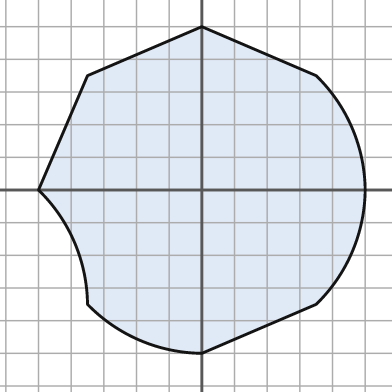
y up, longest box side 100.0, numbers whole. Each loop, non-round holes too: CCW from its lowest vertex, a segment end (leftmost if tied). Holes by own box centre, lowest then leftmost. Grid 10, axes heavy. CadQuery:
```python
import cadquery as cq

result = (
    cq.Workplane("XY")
    .moveTo(0.0, -50.0)
    .lineTo(35.0, -35.0)
    .threePointArc((46.0, -19.0), (50.0, 0.0))
    .threePointArc((46.0, 19.0), (35.0, 35.0))
    .lineTo(0.0, 50.0)
    .lineTo(-35.0, 35.0)
    .lineTo(-50.0, 0.0)
    .threePointArc((-39.0, -16.0), (-35.0, -35.0))
    .threePointArc((-19.0, -46.0), (0.0, -50.0))
    .close()
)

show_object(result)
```